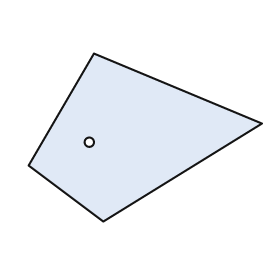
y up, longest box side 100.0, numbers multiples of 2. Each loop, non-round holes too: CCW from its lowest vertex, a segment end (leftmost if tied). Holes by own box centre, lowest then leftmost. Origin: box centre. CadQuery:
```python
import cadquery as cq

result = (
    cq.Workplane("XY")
    .moveTo(-18.0, -36.0)
    .lineTo(50.0, 6.0)
    .lineTo(-22.0, 36.0)
    .lineTo(-50.0, -12.0)
    .close()
    .moveTo(-24.0, -2.0)
    .circle(2.0)
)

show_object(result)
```